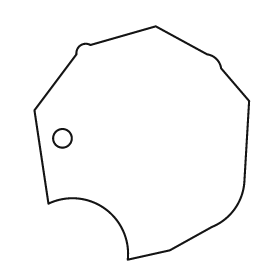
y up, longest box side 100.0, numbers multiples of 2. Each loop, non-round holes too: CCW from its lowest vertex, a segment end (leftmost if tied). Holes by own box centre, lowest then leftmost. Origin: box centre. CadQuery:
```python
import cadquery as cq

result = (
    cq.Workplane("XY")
    .moveTo(-6.0, -50.0)
    .lineTo(12.0, -46.0)
    .lineTo(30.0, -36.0)
    .threePointArc((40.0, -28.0), (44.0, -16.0))
    .lineTo(46.0, 18.0)
    .lineTo(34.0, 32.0)
    .threePointArc((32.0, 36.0), (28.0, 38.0))
    .lineTo(6.0, 50.0)
    .lineTo(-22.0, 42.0)
    .threePointArc((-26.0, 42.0), (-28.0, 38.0))
    .lineTo(-46.0, 14.0)
    .lineTo(-40.0, -26.0)
    .threePointArc((-16.0, -28.0), (-6.0, -50.0))
    .close()
    .moveTo(-34.0, 2.0)
    .circle(4.0)
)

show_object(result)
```